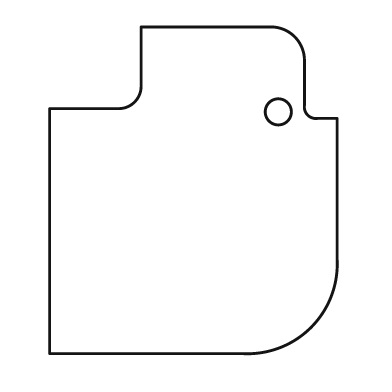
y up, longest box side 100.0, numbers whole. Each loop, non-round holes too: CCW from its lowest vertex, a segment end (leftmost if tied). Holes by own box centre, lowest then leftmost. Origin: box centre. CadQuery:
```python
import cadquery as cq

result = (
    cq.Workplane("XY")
    .moveTo(-44.0, -50.0)
    .lineTo(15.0, -50.0)
    .threePointArc((36.0, -42.0), (44.0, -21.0))
    .lineTo(44.0, 22.0)
    .lineTo(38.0, 22.0)
    .threePointArc((35.0, 23.0), (34.0, 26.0))
    .lineTo(34.0, 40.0)
    .threePointArc((31.0, 47.0), (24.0, 50.0))
    .lineTo(-16.0, 50.0)
    .lineTo(-16.0, 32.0)
    .threePointArc((-18.0, 27.0), (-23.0, 25.0))
    .lineTo(-44.0, 25.0)
    .close()
    .moveTo(26.0, 24.0)
    .circle(4.0)
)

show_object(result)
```